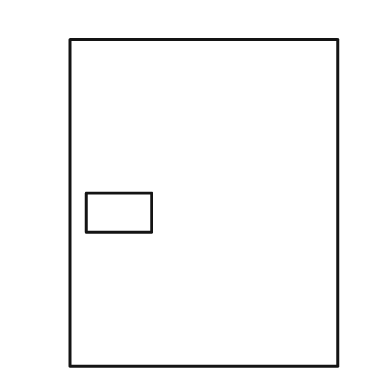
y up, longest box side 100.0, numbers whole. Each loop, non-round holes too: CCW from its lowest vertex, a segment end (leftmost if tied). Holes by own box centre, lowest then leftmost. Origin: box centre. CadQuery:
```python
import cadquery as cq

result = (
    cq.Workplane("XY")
    .moveTo(-41.0, -50.0)
    .lineTo(41.0, -50.0)
    .lineTo(41.0, 50.0)
    .lineTo(-41.0, 50.0)
    .close()
    .moveTo(-36.0, -9.0)
    .lineTo(-16.0, -9.0)
    .lineTo(-16.0, 3.0)
    .lineTo(-36.0, 3.0)
    .close()
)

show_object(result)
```